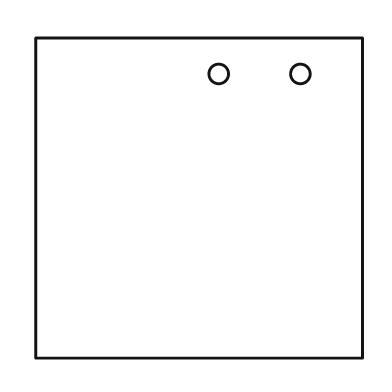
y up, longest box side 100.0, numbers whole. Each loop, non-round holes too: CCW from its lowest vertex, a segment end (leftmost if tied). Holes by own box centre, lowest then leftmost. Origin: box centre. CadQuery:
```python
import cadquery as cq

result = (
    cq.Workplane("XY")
    .moveTo(-50.0, -49.0)
    .lineTo(50.0, -49.0)
    .lineTo(50.0, 49.0)
    .lineTo(-50.0, 49.0)
    .close()
    .moveTo(6.0, 38.0)
    .circle(3.0)
    .moveTo(31.0, 38.0)
    .circle(3.0)
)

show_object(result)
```